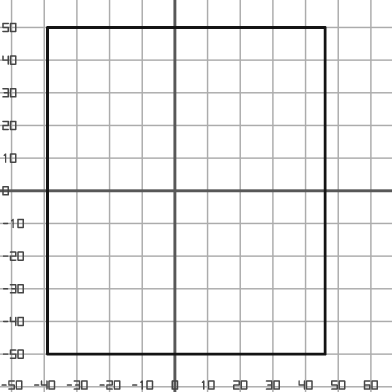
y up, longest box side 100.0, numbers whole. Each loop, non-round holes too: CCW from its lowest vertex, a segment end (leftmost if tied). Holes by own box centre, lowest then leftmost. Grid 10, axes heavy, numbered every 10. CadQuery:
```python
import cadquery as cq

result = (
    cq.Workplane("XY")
    .moveTo(-39.0, -50.0)
    .lineTo(46.0, -50.0)
    .lineTo(46.0, 50.0)
    .lineTo(-39.0, 50.0)
    .close()
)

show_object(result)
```